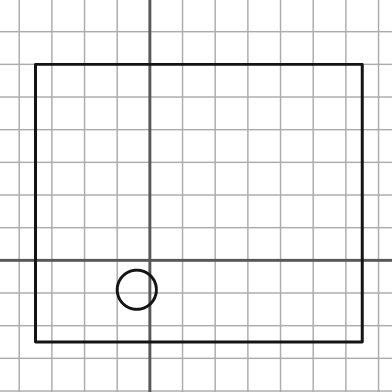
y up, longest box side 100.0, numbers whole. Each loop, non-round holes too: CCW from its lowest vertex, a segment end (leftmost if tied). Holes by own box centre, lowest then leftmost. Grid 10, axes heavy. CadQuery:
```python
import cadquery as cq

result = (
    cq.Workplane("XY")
    .moveTo(-35.0, -25.0)
    .lineTo(65.0, -25.0)
    .lineTo(65.0, 60.0)
    .lineTo(-35.0, 60.0)
    .close()
    .moveTo(-4.0, -9.0)
    .circle(6.0)
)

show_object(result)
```